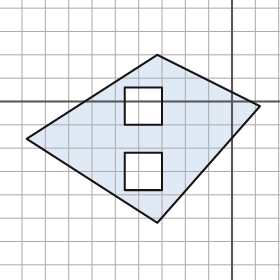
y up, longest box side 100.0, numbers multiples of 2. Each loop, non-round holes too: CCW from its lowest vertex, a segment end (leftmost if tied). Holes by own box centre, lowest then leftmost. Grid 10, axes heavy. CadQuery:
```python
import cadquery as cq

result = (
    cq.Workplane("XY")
    .moveTo(-32.0, -52.0)
    .lineTo(12.0, -2.0)
    .lineTo(-32.0, 20.0)
    .lineTo(-88.0, -16.0)
    .close()
    .moveTo(-46.0, -38.0)
    .lineTo(-30.0, -38.0)
    .lineTo(-30.0, -22.0)
    .lineTo(-46.0, -22.0)
    .close()
    .moveTo(-46.0, -10.0)
    .lineTo(-30.0, -10.0)
    .lineTo(-30.0, 6.0)
    .lineTo(-46.0, 6.0)
    .close()
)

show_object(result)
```